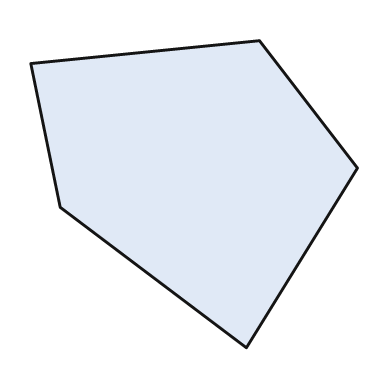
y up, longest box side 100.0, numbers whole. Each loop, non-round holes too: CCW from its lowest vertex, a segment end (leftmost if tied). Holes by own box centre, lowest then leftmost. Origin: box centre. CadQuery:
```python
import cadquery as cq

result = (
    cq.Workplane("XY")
    .moveTo(16.0, -47.0)
    .lineTo(50.0, 8.0)
    .lineTo(20.0, 47.0)
    .lineTo(-50.0, 40.0)
    .lineTo(-41.0, -4.0)
    .close()
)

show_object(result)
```